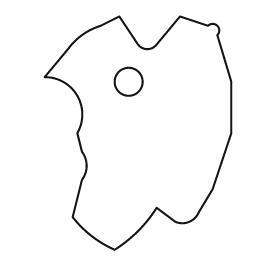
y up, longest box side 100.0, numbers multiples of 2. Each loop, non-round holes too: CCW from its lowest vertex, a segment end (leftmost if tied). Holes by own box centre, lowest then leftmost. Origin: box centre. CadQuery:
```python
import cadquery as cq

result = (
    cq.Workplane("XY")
    .moveTo(-10.0, -50.0)
    .threePointArc((0.0, -42.0), (8.0, -32.0))
    .lineTo(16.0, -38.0)
    .threePointArc((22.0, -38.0), (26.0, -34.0))
    .lineTo(32.0, -24.0)
    .lineTo(40.0, 0.0)
    .lineTo(40.0, 22.0)
    .lineTo(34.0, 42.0)
    .threePointArc((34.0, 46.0), (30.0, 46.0))
    .lineTo(18.0, 50.0)
    .lineTo(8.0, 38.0)
    .threePointArc((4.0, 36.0), (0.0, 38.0))
    .lineTo(-8.0, 50.0)
    .lineTo(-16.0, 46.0)
    .threePointArc((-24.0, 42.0), (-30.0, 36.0))
    .lineTo(-40.0, 24.0)
    .threePointArc((-26.0, 16.0), (-26.0, 0.0))
    .lineTo(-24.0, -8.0)
    .threePointArc((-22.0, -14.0), (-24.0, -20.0))
    .lineTo(-28.0, -36.0)
    .threePointArc((-20.0, -44.0), (-10.0, -50.0))
    .close()
    .moveTo(-4.0, 22.0)
    .circle(6.0)
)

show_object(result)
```